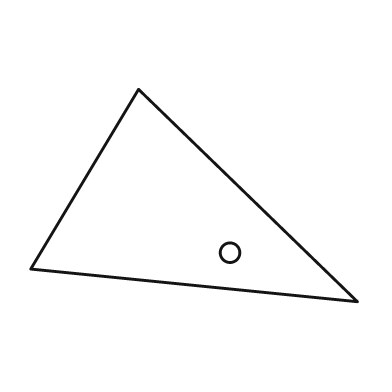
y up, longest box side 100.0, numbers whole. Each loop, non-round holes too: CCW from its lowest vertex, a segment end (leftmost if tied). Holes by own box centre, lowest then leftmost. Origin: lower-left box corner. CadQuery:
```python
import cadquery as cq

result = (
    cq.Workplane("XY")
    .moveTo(100.0, 0.0)
    .lineTo(33.0, 65.0)
    .lineTo(0.0, 10.0)
    .close()
    .moveTo(61.0, 15.0)
    .circle(3.0)
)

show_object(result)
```